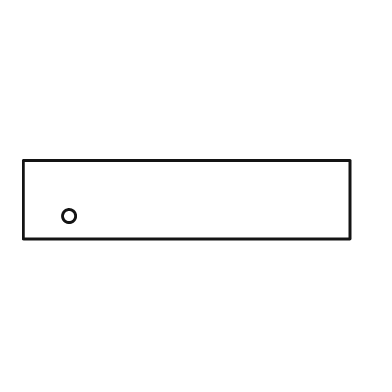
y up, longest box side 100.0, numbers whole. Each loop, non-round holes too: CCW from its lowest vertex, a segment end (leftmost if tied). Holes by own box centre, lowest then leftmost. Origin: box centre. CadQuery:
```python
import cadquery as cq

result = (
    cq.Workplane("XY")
    .moveTo(-50.0, -12.0)
    .lineTo(50.0, -12.0)
    .lineTo(50.0, 12.0)
    .lineTo(-50.0, 12.0)
    .close()
    .moveTo(-36.0, -5.0)
    .circle(2.0)
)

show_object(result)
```